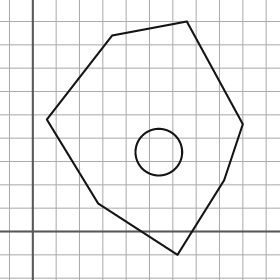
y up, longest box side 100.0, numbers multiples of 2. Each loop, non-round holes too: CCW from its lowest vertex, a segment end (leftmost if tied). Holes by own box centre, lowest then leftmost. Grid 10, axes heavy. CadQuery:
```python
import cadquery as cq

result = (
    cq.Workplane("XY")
    .moveTo(62.0, -10.0)
    .lineTo(82.0, 22.0)
    .lineTo(90.0, 46.0)
    .lineTo(66.0, 90.0)
    .lineTo(34.0, 84.0)
    .lineTo(6.0, 48.0)
    .lineTo(28.0, 12.0)
    .close()
    .moveTo(54.0, 34.0)
    .circle(10.0)
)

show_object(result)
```